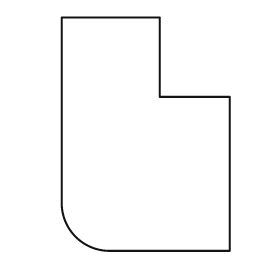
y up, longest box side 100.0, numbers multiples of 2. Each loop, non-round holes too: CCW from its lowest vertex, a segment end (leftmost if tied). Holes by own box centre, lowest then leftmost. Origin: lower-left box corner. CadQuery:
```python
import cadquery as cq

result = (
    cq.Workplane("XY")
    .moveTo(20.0, 0.0)
    .lineTo(72.0, 0.0)
    .lineTo(72.0, 66.0)
    .lineTo(42.0, 66.0)
    .lineTo(42.0, 100.0)
    .lineTo(0.0, 100.0)
    .lineTo(0.0, 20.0)
    .threePointArc((6.0, 6.0), (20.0, 0.0))
    .close()
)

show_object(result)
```